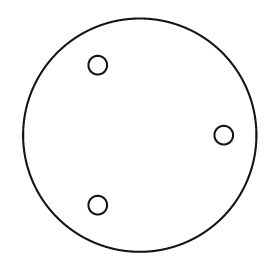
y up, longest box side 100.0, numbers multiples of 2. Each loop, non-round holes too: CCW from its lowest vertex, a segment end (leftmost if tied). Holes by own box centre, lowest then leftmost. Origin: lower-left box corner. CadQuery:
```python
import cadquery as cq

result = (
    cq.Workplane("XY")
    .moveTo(50.0, 50.0)
    .circle(50.0)
    .moveTo(32.0, 20.0)
    .circle(4.0)
    .moveTo(86.0, 50.0)
    .circle(4.0)
    .moveTo(32.0, 80.0)
    .circle(4.0)
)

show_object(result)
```